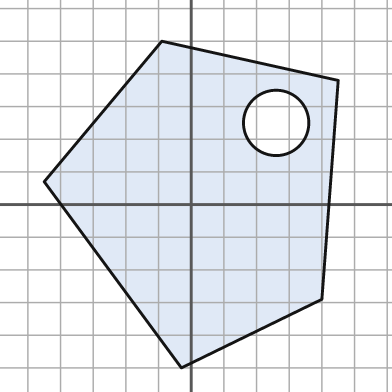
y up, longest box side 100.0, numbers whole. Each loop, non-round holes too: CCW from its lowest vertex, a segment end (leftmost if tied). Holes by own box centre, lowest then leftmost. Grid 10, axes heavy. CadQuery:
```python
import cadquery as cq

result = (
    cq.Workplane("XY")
    .moveTo(-3.0, -50.0)
    .lineTo(40.0, -29.0)
    .lineTo(45.0, 38.0)
    .lineTo(-9.0, 50.0)
    .lineTo(-45.0, 7.0)
    .close()
    .moveTo(26.0, 25.0)
    .circle(10.0)
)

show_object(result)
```